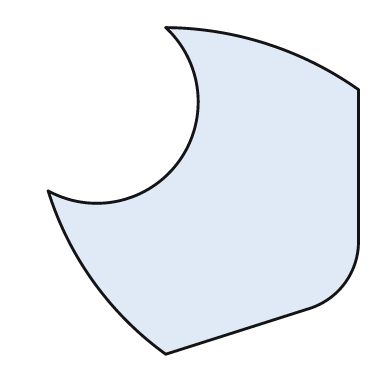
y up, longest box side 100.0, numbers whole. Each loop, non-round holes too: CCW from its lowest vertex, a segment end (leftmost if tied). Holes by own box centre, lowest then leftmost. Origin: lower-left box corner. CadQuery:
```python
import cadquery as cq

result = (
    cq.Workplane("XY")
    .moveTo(36.0, 0.0)
    .lineTo(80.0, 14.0)
    .threePointArc((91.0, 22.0), (95.0, 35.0))
    .lineTo(95.0, 81.0)
    .threePointArc((67.0, 95.0), (36.0, 100.0))
    .threePointArc((40.0, 59.0), (0.0, 50.0))
    .threePointArc((14.0, 22.0), (36.0, 0.0))
    .close()
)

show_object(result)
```